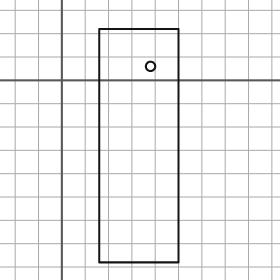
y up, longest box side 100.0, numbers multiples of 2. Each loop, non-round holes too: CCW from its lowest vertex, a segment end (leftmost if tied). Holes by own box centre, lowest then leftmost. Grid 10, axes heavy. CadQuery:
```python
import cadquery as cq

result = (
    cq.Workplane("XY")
    .moveTo(16.0, -78.0)
    .lineTo(50.0, -78.0)
    .lineTo(50.0, 22.0)
    .lineTo(16.0, 22.0)
    .close()
    .moveTo(38.0, 6.0)
    .circle(2.0)
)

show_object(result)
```